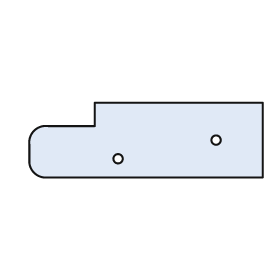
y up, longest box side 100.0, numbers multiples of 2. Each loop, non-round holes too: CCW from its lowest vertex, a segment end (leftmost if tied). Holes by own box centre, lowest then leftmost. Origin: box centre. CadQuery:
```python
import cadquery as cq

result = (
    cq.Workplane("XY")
    .moveTo(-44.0, -16.0)
    .lineTo(50.0, -16.0)
    .lineTo(50.0, 16.0)
    .lineTo(-22.0, 16.0)
    .lineTo(-22.0, 6.0)
    .lineTo(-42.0, 6.0)
    .threePointArc((-48.0, 4.0), (-50.0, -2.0))
    .lineTo(-50.0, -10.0)
    .threePointArc((-48.0, -14.0), (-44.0, -16.0))
    .close()
    .moveTo(-12.0, -8.0)
    .circle(2.0)
    .moveTo(30.0, 0.0)
    .circle(2.0)
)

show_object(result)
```